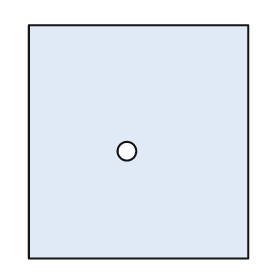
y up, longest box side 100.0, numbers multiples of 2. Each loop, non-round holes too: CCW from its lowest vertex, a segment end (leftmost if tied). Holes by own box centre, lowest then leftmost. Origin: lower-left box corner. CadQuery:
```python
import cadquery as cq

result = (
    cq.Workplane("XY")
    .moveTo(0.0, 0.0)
    .lineTo(94.0, 0.0)
    .lineTo(94.0, 100.0)
    .lineTo(0.0, 100.0)
    .close()
    .moveTo(42.0, 46.0)
    .circle(4.0)
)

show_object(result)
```